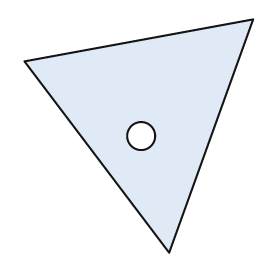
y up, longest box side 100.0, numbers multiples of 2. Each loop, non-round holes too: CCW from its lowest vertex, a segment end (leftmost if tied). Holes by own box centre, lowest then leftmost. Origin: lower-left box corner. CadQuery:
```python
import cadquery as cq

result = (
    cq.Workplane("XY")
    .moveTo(62.0, 0.0)
    .lineTo(98.0, 100.0)
    .lineTo(0.0, 82.0)
    .close()
    .moveTo(50.0, 50.0)
    .circle(6.0)
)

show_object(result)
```